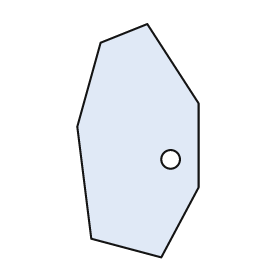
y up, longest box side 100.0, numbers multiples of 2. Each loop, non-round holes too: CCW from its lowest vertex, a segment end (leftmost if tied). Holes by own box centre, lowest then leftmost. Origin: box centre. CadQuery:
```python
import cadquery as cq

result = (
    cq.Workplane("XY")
    .moveTo(10.0, -50.0)
    .lineTo(26.0, -20.0)
    .lineTo(26.0, 16.0)
    .lineTo(4.0, 50.0)
    .lineTo(-16.0, 42.0)
    .lineTo(-26.0, 6.0)
    .lineTo(-20.0, -42.0)
    .close()
    .moveTo(14.0, -8.0)
    .circle(4.0)
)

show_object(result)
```